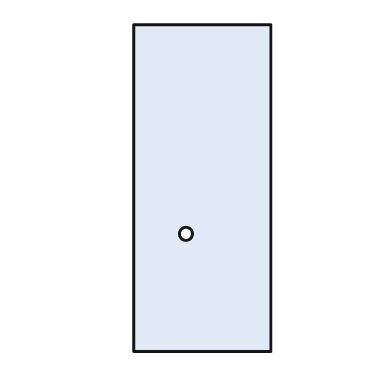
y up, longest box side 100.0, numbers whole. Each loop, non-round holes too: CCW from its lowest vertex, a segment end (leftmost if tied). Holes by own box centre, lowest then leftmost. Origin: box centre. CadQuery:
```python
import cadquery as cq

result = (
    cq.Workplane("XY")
    .moveTo(-21.0, -50.0)
    .lineTo(21.0, -50.0)
    .lineTo(21.0, 50.0)
    .lineTo(-21.0, 50.0)
    .close()
    .moveTo(-5.0, -14.0)
    .circle(2.0)
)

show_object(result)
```